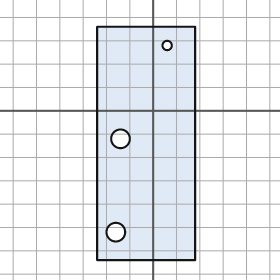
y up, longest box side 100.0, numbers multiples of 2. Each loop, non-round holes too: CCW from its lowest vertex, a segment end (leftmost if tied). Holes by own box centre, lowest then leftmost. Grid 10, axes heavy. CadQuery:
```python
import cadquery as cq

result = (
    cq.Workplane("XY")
    .moveTo(-24.0, -64.0)
    .lineTo(18.0, -64.0)
    .lineTo(18.0, 36.0)
    .lineTo(-24.0, 36.0)
    .close()
    .moveTo(-16.0, -52.0)
    .circle(4.0)
    .moveTo(-14.0, -12.0)
    .circle(4.0)
    .moveTo(6.0, 28.0)
    .circle(2.0)
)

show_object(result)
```